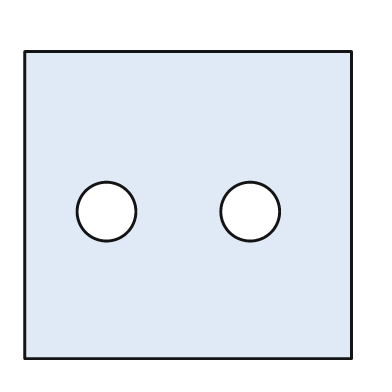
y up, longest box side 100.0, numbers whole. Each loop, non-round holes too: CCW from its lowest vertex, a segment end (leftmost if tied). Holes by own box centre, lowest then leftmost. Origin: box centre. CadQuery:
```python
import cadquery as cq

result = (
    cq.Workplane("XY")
    .moveTo(-50.0, -47.0)
    .lineTo(50.0, -47.0)
    .lineTo(50.0, 47.0)
    .lineTo(-50.0, 47.0)
    .close()
    .moveTo(-25.0, -2.0)
    .circle(9.0)
    .moveTo(19.0, -2.0)
    .circle(9.0)
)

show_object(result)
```